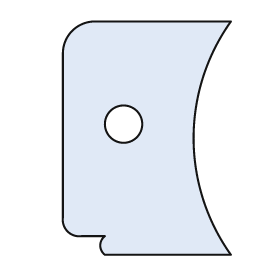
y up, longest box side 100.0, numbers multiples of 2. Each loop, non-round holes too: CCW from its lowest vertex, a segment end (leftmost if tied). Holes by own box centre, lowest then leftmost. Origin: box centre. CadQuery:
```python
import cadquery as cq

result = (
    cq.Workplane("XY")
    .moveTo(-18.0, -50.0)
    .lineTo(36.0, -50.0)
    .threePointArc((20.0, 0.0), (36.0, 50.0))
    .lineTo(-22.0, 50.0)
    .threePointArc((-32.0, 46.0), (-36.0, 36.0))
    .lineTo(-36.0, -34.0)
    .threePointArc((-34.0, -40.0), (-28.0, -42.0))
    .lineTo(-18.0, -42.0)
    .threePointArc((-20.0, -46.0), (-18.0, -50.0))
    .close()
    .moveTo(-10.0, 6.0)
    .circle(8.0)
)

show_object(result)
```